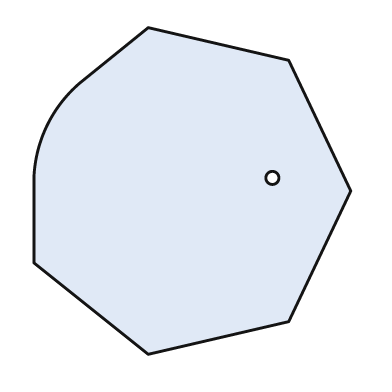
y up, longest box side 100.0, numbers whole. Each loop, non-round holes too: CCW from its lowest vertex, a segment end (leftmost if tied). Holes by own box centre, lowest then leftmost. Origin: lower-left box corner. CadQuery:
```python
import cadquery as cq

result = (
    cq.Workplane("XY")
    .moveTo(35.0, 0.0)
    .lineTo(78.0, 10.0)
    .lineTo(97.0, 50.0)
    .lineTo(78.0, 90.0)
    .lineTo(35.0, 100.0)
    .lineTo(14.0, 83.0)
    .threePointArc((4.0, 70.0), (0.0, 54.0))
    .lineTo(0.0, 28.0)
    .close()
    .moveTo(73.0, 54.0)
    .circle(2.0)
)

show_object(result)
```